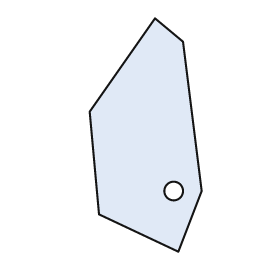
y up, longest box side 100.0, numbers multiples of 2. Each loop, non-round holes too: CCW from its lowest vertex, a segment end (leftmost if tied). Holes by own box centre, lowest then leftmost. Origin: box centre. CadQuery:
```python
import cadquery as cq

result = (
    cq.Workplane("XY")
    .moveTo(14.0, -50.0)
    .lineTo(24.0, -24.0)
    .lineTo(16.0, 40.0)
    .lineTo(4.0, 50.0)
    .lineTo(-24.0, 10.0)
    .lineTo(-20.0, -34.0)
    .close()
    .moveTo(12.0, -24.0)
    .circle(4.0)
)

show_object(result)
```